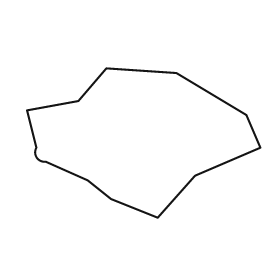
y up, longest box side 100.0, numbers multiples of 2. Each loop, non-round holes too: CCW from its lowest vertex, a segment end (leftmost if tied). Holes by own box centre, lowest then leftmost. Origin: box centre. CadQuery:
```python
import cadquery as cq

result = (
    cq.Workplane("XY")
    .moveTo(6.0, -32.0)
    .lineTo(22.0, -14.0)
    .lineTo(50.0, -2.0)
    .lineTo(44.0, 12.0)
    .lineTo(14.0, 30.0)
    .lineTo(-16.0, 32.0)
    .lineTo(-28.0, 18.0)
    .lineTo(-50.0, 14.0)
    .lineTo(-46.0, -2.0)
    .threePointArc((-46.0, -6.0), (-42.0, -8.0))
    .lineTo(-24.0, -16.0)
    .lineTo(-14.0, -24.0)
    .close()
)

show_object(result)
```